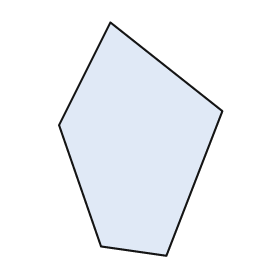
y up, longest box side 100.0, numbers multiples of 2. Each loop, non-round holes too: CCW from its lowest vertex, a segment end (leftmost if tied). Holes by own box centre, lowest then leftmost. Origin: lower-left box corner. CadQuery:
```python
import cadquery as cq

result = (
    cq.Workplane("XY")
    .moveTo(46.0, 0.0)
    .lineTo(70.0, 62.0)
    .lineTo(22.0, 100.0)
    .lineTo(0.0, 56.0)
    .lineTo(18.0, 4.0)
    .close()
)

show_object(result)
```